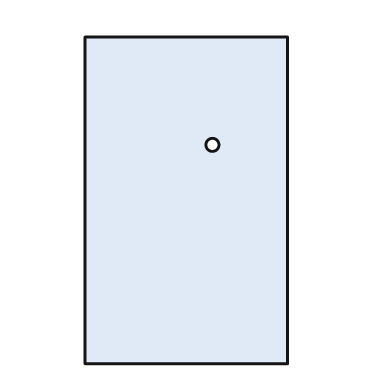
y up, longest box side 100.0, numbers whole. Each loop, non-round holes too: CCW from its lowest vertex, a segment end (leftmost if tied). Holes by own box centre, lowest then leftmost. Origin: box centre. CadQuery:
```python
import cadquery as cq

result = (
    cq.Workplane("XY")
    .moveTo(-31.0, -50.0)
    .lineTo(31.0, -50.0)
    .lineTo(31.0, 50.0)
    .lineTo(-31.0, 50.0)
    .close()
    .moveTo(8.0, 17.0)
    .circle(2.0)
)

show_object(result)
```